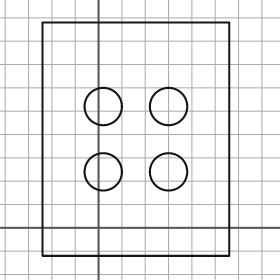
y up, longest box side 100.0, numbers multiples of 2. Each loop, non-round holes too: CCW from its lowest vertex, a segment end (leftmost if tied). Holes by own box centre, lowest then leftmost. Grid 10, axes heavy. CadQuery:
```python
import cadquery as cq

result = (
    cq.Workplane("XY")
    .moveTo(-24.0, -12.0)
    .lineTo(56.0, -12.0)
    .lineTo(56.0, 88.0)
    .lineTo(-24.0, 88.0)
    .close()
    .moveTo(2.0, 24.0)
    .circle(8.0)
    .moveTo(30.0, 24.0)
    .circle(8.0)
    .moveTo(2.0, 52.0)
    .circle(8.0)
    .moveTo(30.0, 52.0)
    .circle(8.0)
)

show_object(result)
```